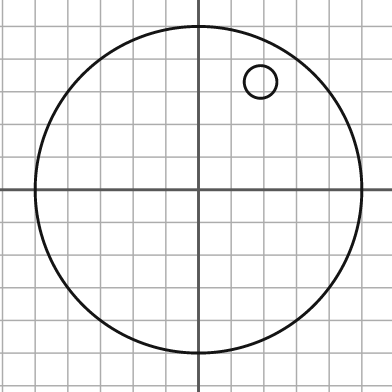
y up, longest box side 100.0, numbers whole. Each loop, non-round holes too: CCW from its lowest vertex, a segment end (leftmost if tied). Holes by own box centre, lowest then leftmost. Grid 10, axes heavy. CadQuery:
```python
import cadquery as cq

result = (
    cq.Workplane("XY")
    .moveTo(0.0, 0.0)
    .circle(50.0)
    .moveTo(19.0, 33.0)
    .circle(5.0)
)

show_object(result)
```